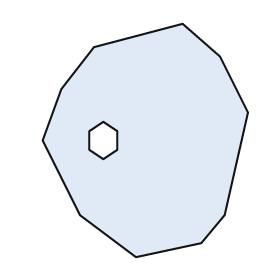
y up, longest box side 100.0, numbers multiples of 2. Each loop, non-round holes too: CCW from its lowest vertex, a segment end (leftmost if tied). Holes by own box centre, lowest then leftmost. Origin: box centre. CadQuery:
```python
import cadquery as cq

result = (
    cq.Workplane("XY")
    .moveTo(-4.0, -50.0)
    .lineTo(24.0, -44.0)
    .lineTo(34.0, -32.0)
    .lineTo(44.0, 12.0)
    .lineTo(32.0, 36.0)
    .lineTo(16.0, 50.0)
    .lineTo(-22.0, 40.0)
    .lineTo(-36.0, 22.0)
    .lineTo(-44.0, 0.0)
    .lineTo(-28.0, -32.0)
    .close()
    .moveTo(-18.0, -8.0)
    .lineTo(-12.0, -4.0)
    .lineTo(-12.0, 4.0)
    .lineTo(-18.0, 8.0)
    .lineTo(-24.0, 4.0)
    .lineTo(-24.0, -4.0)
    .close()
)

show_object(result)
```